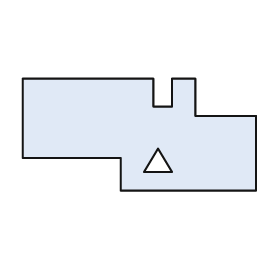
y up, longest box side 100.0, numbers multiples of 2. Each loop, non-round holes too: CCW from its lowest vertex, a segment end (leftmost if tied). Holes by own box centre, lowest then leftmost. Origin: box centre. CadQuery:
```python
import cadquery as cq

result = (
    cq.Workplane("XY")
    .moveTo(-8.0, -24.0)
    .lineTo(50.0, -24.0)
    .lineTo(50.0, 8.0)
    .lineTo(24.0, 8.0)
    .lineTo(24.0, 24.0)
    .lineTo(14.0, 24.0)
    .lineTo(14.0, 12.0)
    .lineTo(6.0, 12.0)
    .lineTo(6.0, 24.0)
    .lineTo(-50.0, 24.0)
    .lineTo(-50.0, -10.0)
    .lineTo(-8.0, -10.0)
    .close()
    .moveTo(2.0, -16.0)
    .lineTo(14.0, -16.0)
    .lineTo(8.0, -6.0)
    .close()
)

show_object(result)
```